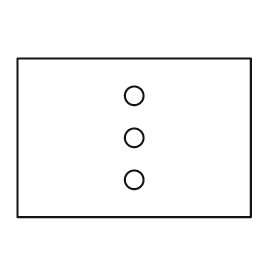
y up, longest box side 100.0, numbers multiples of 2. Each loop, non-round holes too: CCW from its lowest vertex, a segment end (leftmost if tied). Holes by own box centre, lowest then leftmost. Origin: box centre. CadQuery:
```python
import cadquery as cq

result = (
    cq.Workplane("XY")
    .moveTo(-50.0, -34.0)
    .lineTo(50.0, -34.0)
    .lineTo(50.0, 34.0)
    .lineTo(-50.0, 34.0)
    .close()
    .moveTo(0.0, -18.0)
    .circle(4.0)
    .moveTo(0.0, 0.0)
    .circle(4.0)
    .moveTo(0.0, 18.0)
    .circle(4.0)
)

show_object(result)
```